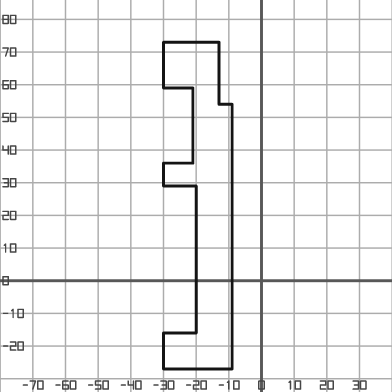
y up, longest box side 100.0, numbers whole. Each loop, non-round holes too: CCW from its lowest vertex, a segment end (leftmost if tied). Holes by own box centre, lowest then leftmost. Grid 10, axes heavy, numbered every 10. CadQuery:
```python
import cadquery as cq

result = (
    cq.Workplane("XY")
    .moveTo(-30.0, -27.0)
    .lineTo(-9.0, -27.0)
    .lineTo(-9.0, 54.0)
    .lineTo(-13.0, 54.0)
    .lineTo(-13.0, 73.0)
    .lineTo(-30.0, 73.0)
    .lineTo(-30.0, 59.0)
    .lineTo(-21.0, 59.0)
    .lineTo(-21.0, 36.0)
    .lineTo(-30.0, 36.0)
    .lineTo(-30.0, 29.0)
    .lineTo(-20.0, 29.0)
    .lineTo(-20.0, -16.0)
    .lineTo(-30.0, -16.0)
    .close()
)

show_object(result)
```